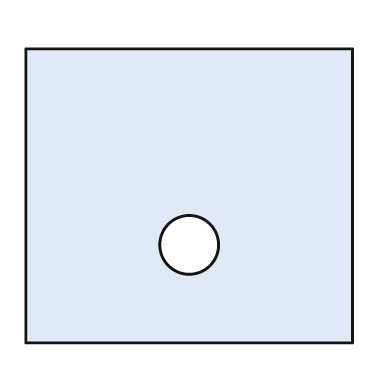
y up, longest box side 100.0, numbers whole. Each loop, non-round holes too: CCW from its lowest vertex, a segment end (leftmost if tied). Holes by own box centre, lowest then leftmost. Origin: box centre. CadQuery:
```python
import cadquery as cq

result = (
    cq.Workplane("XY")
    .moveTo(-50.0, -45.0)
    .lineTo(50.0, -45.0)
    .lineTo(50.0, 45.0)
    .lineTo(-50.0, 45.0)
    .close()
    .moveTo(0.0, -15.0)
    .circle(9.0)
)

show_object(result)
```